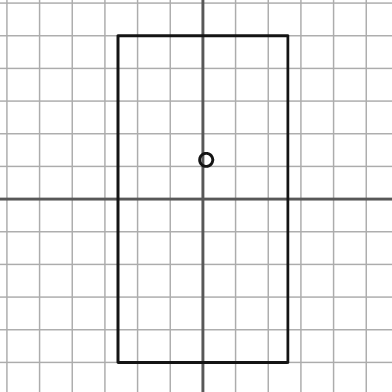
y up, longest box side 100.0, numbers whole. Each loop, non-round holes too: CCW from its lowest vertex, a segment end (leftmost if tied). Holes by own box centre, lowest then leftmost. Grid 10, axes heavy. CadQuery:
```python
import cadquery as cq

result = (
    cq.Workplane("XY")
    .moveTo(-26.0, -50.0)
    .lineTo(26.0, -50.0)
    .lineTo(26.0, 50.0)
    .lineTo(-26.0, 50.0)
    .close()
    .moveTo(1.0, 12.0)
    .circle(2.0)
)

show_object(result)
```